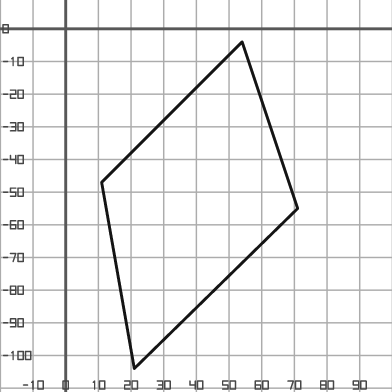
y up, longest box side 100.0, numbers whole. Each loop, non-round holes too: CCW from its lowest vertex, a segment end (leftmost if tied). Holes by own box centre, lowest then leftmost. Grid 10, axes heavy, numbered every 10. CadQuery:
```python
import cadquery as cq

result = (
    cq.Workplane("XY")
    .moveTo(21.0, -104.0)
    .lineTo(71.0, -55.0)
    .lineTo(54.0, -4.0)
    .lineTo(11.0, -47.0)
    .close()
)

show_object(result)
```